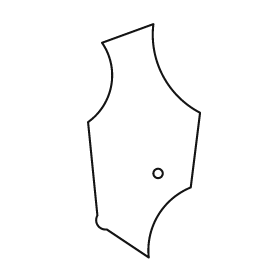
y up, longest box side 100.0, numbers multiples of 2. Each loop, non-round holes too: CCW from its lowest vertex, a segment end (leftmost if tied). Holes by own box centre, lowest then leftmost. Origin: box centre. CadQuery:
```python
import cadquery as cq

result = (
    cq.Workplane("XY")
    .moveTo(2.0, -50.0)
    .threePointArc((6.0, -32.0), (20.0, -20.0))
    .lineTo(24.0, 12.0)
    .threePointArc((8.0, 28.0), (4.0, 50.0))
    .lineTo(-18.0, 42.0)
    .threePointArc((-14.0, 24.0), (-24.0, 8.0))
    .lineTo(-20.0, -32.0)
    .threePointArc((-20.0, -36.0), (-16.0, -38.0))
    .close()
    .moveTo(6.0, -14.0)
    .circle(2.0)
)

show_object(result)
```